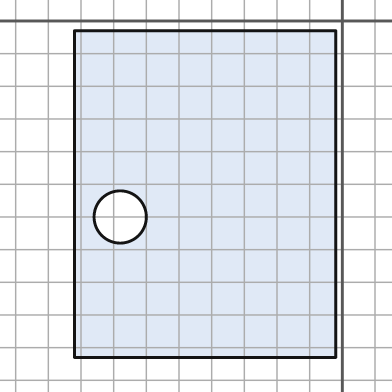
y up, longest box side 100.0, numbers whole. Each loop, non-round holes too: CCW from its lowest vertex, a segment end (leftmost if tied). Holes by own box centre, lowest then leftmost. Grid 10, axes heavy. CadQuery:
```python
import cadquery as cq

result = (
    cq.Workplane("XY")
    .moveTo(-82.0, -103.0)
    .lineTo(-2.0, -103.0)
    .lineTo(-2.0, -3.0)
    .lineTo(-82.0, -3.0)
    .close()
    .moveTo(-68.0, -60.0)
    .circle(8.0)
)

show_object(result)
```